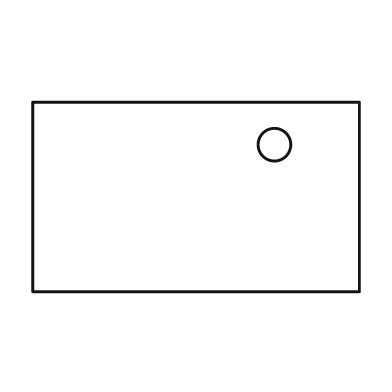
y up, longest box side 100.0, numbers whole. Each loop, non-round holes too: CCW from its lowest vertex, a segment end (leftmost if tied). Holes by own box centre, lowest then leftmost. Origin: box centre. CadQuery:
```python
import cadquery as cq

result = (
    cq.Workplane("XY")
    .moveTo(-50.0, -29.0)
    .lineTo(50.0, -29.0)
    .lineTo(50.0, 29.0)
    .lineTo(-50.0, 29.0)
    .close()
    .moveTo(24.0, 16.0)
    .circle(5.0)
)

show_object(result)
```